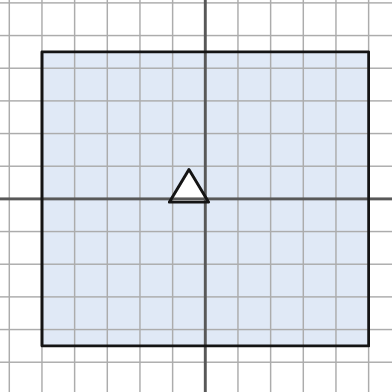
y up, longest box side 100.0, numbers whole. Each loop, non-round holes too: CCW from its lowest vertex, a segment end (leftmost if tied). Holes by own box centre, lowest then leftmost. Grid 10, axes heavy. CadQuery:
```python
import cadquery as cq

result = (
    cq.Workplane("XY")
    .moveTo(-50.0, -45.0)
    .lineTo(50.0, -45.0)
    .lineTo(50.0, 45.0)
    .lineTo(-50.0, 45.0)
    .close()
    .moveTo(-11.0, -1.0)
    .lineTo(1.0, -1.0)
    .lineTo(-5.0, 9.0)
    .close()
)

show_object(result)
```